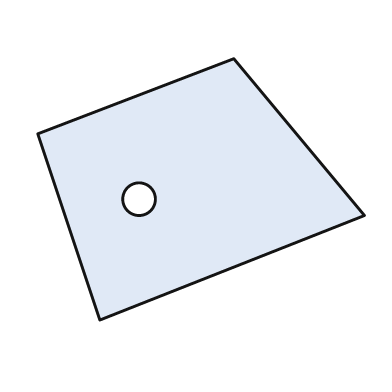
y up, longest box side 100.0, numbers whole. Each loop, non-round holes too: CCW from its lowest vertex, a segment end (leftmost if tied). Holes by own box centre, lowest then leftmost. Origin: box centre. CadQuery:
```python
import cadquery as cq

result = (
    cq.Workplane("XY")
    .moveTo(-31.0, -40.0)
    .lineTo(50.0, -8.0)
    .lineTo(10.0, 40.0)
    .lineTo(-50.0, 17.0)
    .close()
    .moveTo(-19.0, -3.0)
    .circle(5.0)
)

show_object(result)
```